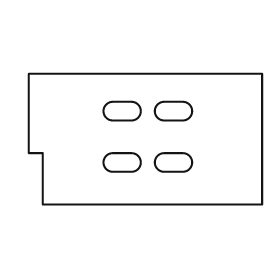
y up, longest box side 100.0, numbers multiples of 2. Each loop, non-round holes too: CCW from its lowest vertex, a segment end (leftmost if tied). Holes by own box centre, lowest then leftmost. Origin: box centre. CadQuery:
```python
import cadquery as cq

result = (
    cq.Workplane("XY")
    .moveTo(-44.0, -28.0)
    .lineTo(50.0, -28.0)
    .lineTo(50.0, 28.0)
    .lineTo(-50.0, 28.0)
    .lineTo(-50.0, -6.0)
    .lineTo(-44.0, -6.0)
    .close()
    .moveTo(-14.0, -14.0)
    .lineTo(-6.0, -14.0)
    .threePointArc((-2.0, -10.0), (-6.0, -6.0))
    .lineTo(-14.0, -6.0)
    .threePointArc((-18.0, -10.0), (-14.0, -14.0))
    .close()
    .moveTo(8.0, -14.0)
    .lineTo(16.0, -14.0)
    .threePointArc((20.0, -10.0), (16.0, -6.0))
    .lineTo(8.0, -6.0)
    .threePointArc((4.0, -10.0), (8.0, -14.0))
    .close()
    .moveTo(-14.0, 8.0)
    .lineTo(-6.0, 8.0)
    .threePointArc((-2.0, 12.0), (-6.0, 16.0))
    .lineTo(-14.0, 16.0)
    .threePointArc((-18.0, 12.0), (-14.0, 8.0))
    .close()
    .moveTo(8.0, 8.0)
    .lineTo(16.0, 8.0)
    .threePointArc((20.0, 12.0), (16.0, 16.0))
    .lineTo(8.0, 16.0)
    .threePointArc((4.0, 12.0), (8.0, 8.0))
    .close()
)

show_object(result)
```